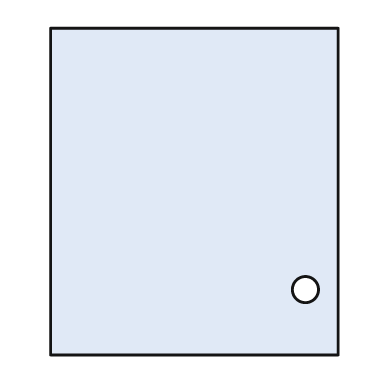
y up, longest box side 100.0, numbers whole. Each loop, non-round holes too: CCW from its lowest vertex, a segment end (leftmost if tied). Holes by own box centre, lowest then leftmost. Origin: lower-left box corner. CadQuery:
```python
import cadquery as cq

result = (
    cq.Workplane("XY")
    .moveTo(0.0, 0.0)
    .lineTo(88.0, 0.0)
    .lineTo(88.0, 100.0)
    .lineTo(0.0, 100.0)
    .close()
    .moveTo(78.0, 20.0)
    .circle(4.0)
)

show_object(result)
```